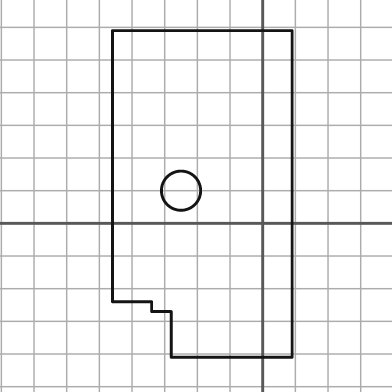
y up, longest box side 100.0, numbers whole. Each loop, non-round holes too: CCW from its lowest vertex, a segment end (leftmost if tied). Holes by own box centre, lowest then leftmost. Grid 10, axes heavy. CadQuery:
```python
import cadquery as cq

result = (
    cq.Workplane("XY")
    .moveTo(-28.0, -41.0)
    .lineTo(9.0, -41.0)
    .lineTo(9.0, 59.0)
    .lineTo(-46.0, 59.0)
    .lineTo(-46.0, -24.0)
    .lineTo(-34.0, -24.0)
    .lineTo(-34.0, -27.0)
    .lineTo(-28.0, -27.0)
    .close()
    .moveTo(-25.0, 10.0)
    .circle(6.0)
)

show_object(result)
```